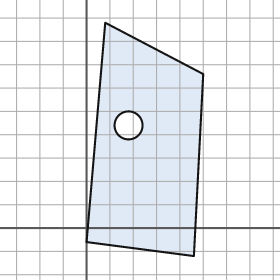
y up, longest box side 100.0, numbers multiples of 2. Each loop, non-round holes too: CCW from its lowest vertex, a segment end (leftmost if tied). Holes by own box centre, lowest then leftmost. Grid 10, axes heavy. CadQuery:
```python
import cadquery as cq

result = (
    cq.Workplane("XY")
    .moveTo(46.0, -12.0)
    .lineTo(50.0, 66.0)
    .lineTo(8.0, 88.0)
    .lineTo(0.0, -6.0)
    .close()
    .moveTo(18.0, 44.0)
    .circle(6.0)
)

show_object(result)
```